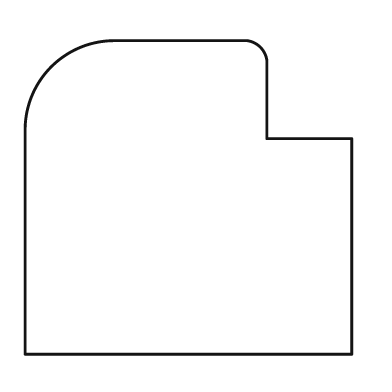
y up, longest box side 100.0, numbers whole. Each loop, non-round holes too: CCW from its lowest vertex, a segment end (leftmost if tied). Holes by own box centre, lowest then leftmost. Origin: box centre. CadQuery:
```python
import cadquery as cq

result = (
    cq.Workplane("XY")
    .moveTo(-50.0, -48.0)
    .lineTo(50.0, -48.0)
    .lineTo(50.0, 18.0)
    .lineTo(24.0, 18.0)
    .lineTo(24.0, 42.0)
    .threePointArc((22.0, 46.0), (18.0, 48.0))
    .lineTo(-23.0, 48.0)
    .threePointArc((-42.0, 40.0), (-50.0, 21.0))
    .close()
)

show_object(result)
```